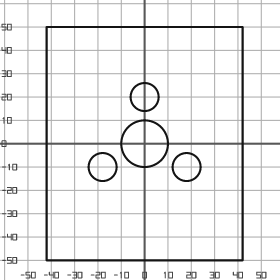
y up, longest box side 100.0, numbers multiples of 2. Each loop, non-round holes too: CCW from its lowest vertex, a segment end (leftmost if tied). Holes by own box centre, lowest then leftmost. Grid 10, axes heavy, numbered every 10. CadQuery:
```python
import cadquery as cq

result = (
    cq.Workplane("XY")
    .moveTo(-42.0, -50.0)
    .lineTo(42.0, -50.0)
    .lineTo(42.0, 50.0)
    .lineTo(-42.0, 50.0)
    .close()
    .moveTo(-18.0, -10.0)
    .circle(6.0)
    .moveTo(18.0, -10.0)
    .circle(6.0)
    .moveTo(0.0, 0.0)
    .circle(10.0)
    .moveTo(0.0, 20.0)
    .circle(6.0)
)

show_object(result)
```